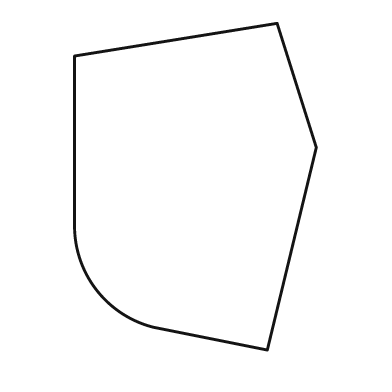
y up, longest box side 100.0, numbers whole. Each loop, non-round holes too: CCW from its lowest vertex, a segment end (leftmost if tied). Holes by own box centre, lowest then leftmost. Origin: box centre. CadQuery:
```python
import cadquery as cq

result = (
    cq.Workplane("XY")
    .moveTo(22.0, -50.0)
    .lineTo(37.0, 12.0)
    .lineTo(25.0, 50.0)
    .lineTo(-37.0, 40.0)
    .lineTo(-37.0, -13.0)
    .threePointArc((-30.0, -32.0), (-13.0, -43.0))
    .close()
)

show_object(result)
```